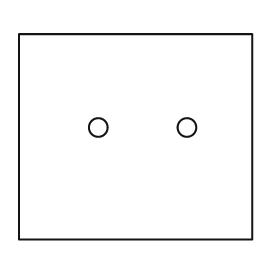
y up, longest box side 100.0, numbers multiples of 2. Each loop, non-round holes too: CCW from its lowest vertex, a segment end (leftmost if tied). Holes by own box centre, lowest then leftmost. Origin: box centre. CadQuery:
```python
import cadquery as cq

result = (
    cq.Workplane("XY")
    .moveTo(-50.0, -44.0)
    .lineTo(50.0, -44.0)
    .lineTo(50.0, 44.0)
    .lineTo(-50.0, 44.0)
    .close()
    .moveTo(-16.0, 4.0)
    .circle(4.0)
    .moveTo(22.0, 4.0)
    .circle(4.0)
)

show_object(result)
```